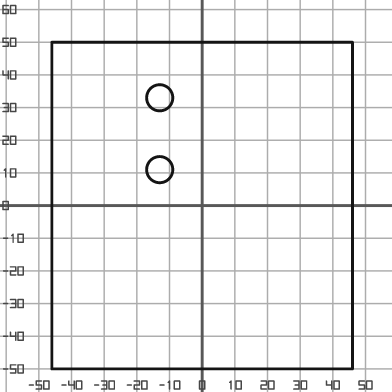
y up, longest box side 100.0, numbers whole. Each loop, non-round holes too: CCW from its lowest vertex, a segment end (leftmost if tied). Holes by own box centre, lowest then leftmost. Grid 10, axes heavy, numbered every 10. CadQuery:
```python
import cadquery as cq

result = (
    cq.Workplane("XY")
    .moveTo(-46.0, -50.0)
    .lineTo(46.0, -50.0)
    .lineTo(46.0, 50.0)
    .lineTo(-46.0, 50.0)
    .close()
    .moveTo(-13.0, 11.0)
    .circle(4.0)
    .moveTo(-13.0, 33.0)
    .circle(4.0)
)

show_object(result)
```